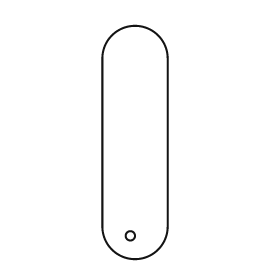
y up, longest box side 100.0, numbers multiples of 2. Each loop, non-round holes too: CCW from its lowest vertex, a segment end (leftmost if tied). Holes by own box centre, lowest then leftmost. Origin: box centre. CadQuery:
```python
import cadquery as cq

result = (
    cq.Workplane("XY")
    .moveTo(-14.0, -36.0)
    .threePointArc((0.0, -50.0), (14.0, -36.0))
    .lineTo(14.0, 36.0)
    .threePointArc((0.0, 50.0), (-14.0, 36.0))
    .close()
    .moveTo(-2.0, -40.0)
    .circle(2.0)
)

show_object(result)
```